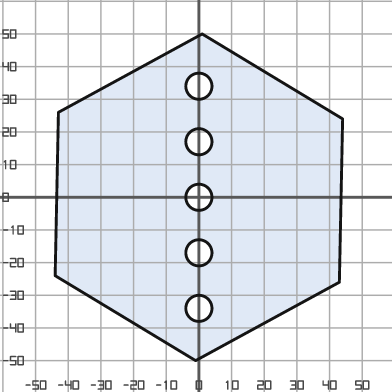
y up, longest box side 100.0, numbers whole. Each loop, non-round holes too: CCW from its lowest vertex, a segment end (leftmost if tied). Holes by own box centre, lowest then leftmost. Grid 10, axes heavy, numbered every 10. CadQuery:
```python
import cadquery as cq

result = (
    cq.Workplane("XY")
    .moveTo(-1.0, -50.0)
    .lineTo(43.0, -26.0)
    .lineTo(44.0, 24.0)
    .lineTo(1.0, 50.0)
    .lineTo(-43.0, 26.0)
    .lineTo(-44.0, -24.0)
    .close()
    .moveTo(0.0, -34.0)
    .circle(4.0)
    .moveTo(0.0, -17.0)
    .circle(4.0)
    .moveTo(0.0, 0.0)
    .circle(4.0)
    .moveTo(0.0, 17.0)
    .circle(4.0)
    .moveTo(0.0, 34.0)
    .circle(4.0)
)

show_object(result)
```